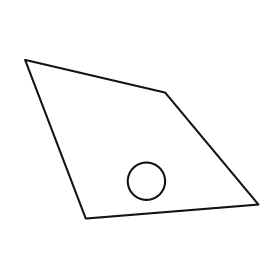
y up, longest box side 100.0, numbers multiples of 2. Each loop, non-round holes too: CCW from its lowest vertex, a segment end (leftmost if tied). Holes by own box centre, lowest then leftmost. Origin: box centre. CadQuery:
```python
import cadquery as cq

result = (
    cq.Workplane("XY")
    .moveTo(-24.0, -34.0)
    .lineTo(50.0, -28.0)
    .lineTo(10.0, 20.0)
    .lineTo(-50.0, 34.0)
    .close()
    .moveTo(2.0, -18.0)
    .circle(8.0)
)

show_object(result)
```